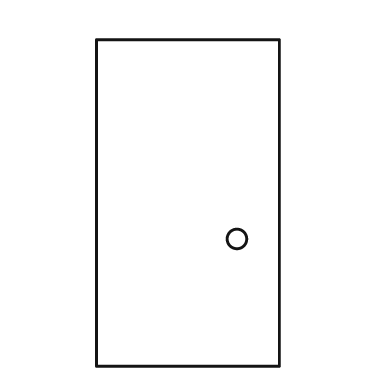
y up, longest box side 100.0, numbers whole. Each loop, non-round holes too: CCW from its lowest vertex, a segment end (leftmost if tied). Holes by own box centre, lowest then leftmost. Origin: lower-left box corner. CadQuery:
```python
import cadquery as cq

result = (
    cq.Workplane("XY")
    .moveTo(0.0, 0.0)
    .lineTo(56.0, 0.0)
    .lineTo(56.0, 100.0)
    .lineTo(0.0, 100.0)
    .close()
    .moveTo(43.0, 39.0)
    .circle(3.0)
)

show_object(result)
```